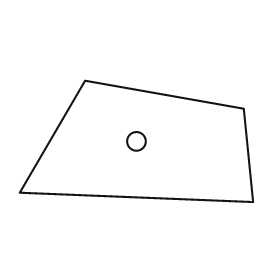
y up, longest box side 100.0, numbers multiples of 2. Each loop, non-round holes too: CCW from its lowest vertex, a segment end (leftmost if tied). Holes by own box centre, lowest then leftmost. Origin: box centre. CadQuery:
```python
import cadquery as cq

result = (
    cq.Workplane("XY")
    .moveTo(50.0, -26.0)
    .lineTo(46.0, 14.0)
    .lineTo(-22.0, 26.0)
    .lineTo(-50.0, -22.0)
    .close()
    .moveTo(0.0, 0.0)
    .circle(4.0)
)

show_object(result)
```